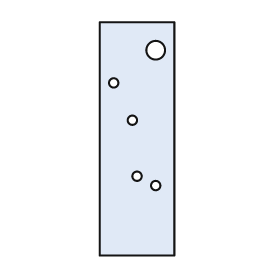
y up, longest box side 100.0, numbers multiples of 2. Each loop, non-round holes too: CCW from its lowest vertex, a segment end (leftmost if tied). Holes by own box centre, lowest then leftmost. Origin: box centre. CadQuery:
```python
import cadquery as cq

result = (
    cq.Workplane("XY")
    .moveTo(-16.0, -50.0)
    .lineTo(16.0, -50.0)
    .lineTo(16.0, 50.0)
    .lineTo(-16.0, 50.0)
    .close()
    .moveTo(8.0, -20.0)
    .circle(2.0)
    .moveTo(0.0, -16.0)
    .circle(2.0)
    .moveTo(-2.0, 8.0)
    .circle(2.0)
    .moveTo(-10.0, 24.0)
    .circle(2.0)
    .moveTo(8.0, 38.0)
    .circle(4.0)
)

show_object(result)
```